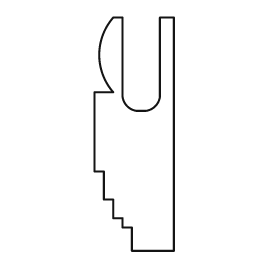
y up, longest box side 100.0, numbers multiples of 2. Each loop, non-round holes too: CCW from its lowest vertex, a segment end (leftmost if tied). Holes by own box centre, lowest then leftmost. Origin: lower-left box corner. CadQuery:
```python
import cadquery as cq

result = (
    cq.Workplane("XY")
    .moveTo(16.0, 0.0)
    .lineTo(34.0, 0.0)
    .lineTo(34.0, 100.0)
    .lineTo(28.0, 100.0)
    .lineTo(28.0, 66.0)
    .threePointArc((26.0, 62.0), (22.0, 60.0))
    .lineTo(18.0, 60.0)
    .threePointArc((14.0, 62.0), (12.0, 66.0))
    .lineTo(12.0, 100.0)
    .lineTo(8.0, 100.0)
    .threePointArc((2.0, 84.0), (8.0, 68.0))
    .lineTo(0.0, 68.0)
    .lineTo(0.0, 34.0)
    .lineTo(4.0, 34.0)
    .lineTo(4.0, 22.0)
    .lineTo(8.0, 22.0)
    .lineTo(8.0, 14.0)
    .lineTo(12.0, 14.0)
    .lineTo(12.0, 10.0)
    .lineTo(16.0, 10.0)
    .close()
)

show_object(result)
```